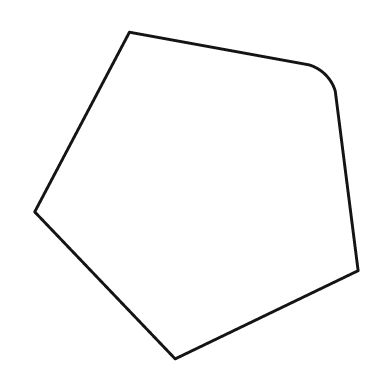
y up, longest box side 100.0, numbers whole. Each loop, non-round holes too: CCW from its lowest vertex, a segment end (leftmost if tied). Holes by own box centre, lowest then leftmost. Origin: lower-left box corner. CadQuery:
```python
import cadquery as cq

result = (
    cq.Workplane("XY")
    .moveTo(43.0, 0.0)
    .lineTo(99.0, 27.0)
    .lineTo(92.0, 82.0)
    .threePointArc((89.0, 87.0), (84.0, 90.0))
    .lineTo(29.0, 100.0)
    .lineTo(0.0, 45.0)
    .close()
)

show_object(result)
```